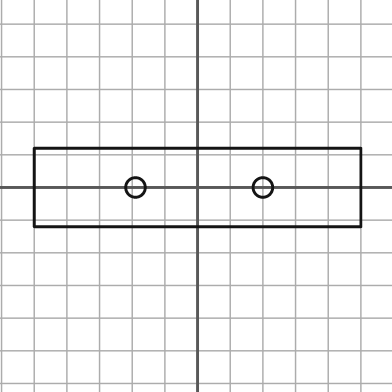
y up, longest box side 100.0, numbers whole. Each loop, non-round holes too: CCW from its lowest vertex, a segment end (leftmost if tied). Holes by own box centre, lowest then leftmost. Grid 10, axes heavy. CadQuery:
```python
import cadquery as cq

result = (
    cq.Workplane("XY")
    .moveTo(-50.0, -12.0)
    .lineTo(50.0, -12.0)
    .lineTo(50.0, 12.0)
    .lineTo(-50.0, 12.0)
    .close()
    .moveTo(-19.0, 0.0)
    .circle(3.0)
    .moveTo(20.0, 0.0)
    .circle(3.0)
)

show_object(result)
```